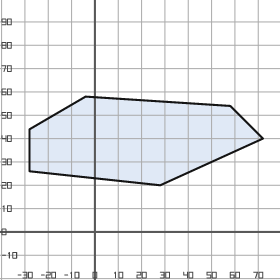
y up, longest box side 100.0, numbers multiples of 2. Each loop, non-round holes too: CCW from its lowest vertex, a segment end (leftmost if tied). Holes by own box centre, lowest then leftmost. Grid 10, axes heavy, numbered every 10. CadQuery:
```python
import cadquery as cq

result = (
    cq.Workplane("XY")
    .moveTo(28.0, 20.0)
    .lineTo(72.0, 40.0)
    .lineTo(58.0, 54.0)
    .lineTo(-4.0, 58.0)
    .lineTo(-28.0, 44.0)
    .lineTo(-28.0, 26.0)
    .close()
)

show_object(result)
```